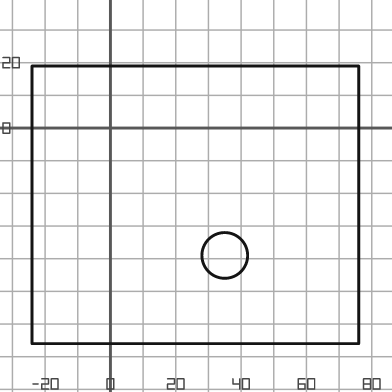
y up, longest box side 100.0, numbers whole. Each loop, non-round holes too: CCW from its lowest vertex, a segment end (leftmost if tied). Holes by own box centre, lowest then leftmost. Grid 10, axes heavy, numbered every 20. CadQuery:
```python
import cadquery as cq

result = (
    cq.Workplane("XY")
    .moveTo(-24.0, -66.0)
    .lineTo(76.0, -66.0)
    .lineTo(76.0, 19.0)
    .lineTo(-24.0, 19.0)
    .close()
    .moveTo(35.0, -39.0)
    .circle(7.0)
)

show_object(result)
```